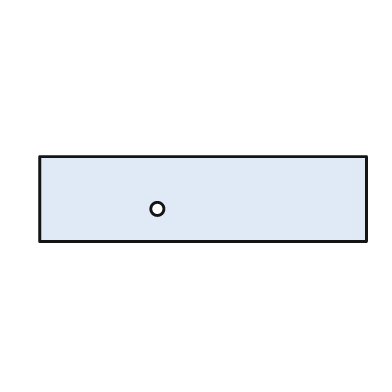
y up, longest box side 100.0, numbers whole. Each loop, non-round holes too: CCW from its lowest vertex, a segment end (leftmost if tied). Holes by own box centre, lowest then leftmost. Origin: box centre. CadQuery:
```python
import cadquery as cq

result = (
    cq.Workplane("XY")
    .moveTo(-50.0, -13.0)
    .lineTo(50.0, -13.0)
    .lineTo(50.0, 13.0)
    .lineTo(-50.0, 13.0)
    .close()
    .moveTo(-14.0, -3.0)
    .circle(2.0)
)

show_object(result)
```